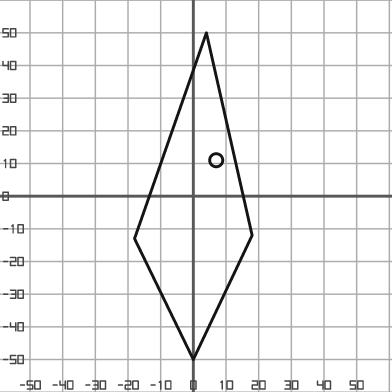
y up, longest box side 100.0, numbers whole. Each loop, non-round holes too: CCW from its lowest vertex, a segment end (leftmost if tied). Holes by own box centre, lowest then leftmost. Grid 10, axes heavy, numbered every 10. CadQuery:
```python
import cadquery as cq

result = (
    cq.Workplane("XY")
    .moveTo(0.0, -50.0)
    .lineTo(18.0, -12.0)
    .lineTo(4.0, 50.0)
    .lineTo(-18.0, -13.0)
    .close()
    .moveTo(7.0, 11.0)
    .circle(2.0)
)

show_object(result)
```